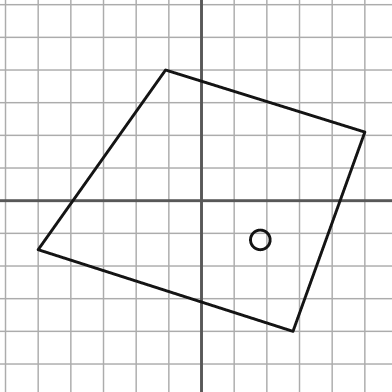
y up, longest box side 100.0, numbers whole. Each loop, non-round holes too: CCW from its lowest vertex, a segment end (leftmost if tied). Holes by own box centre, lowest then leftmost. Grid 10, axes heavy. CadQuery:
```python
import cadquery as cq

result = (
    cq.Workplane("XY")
    .moveTo(28.0, -40.0)
    .lineTo(50.0, 21.0)
    .lineTo(-11.0, 40.0)
    .lineTo(-50.0, -15.0)
    .close()
    .moveTo(18.0, -12.0)
    .circle(3.0)
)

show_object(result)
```